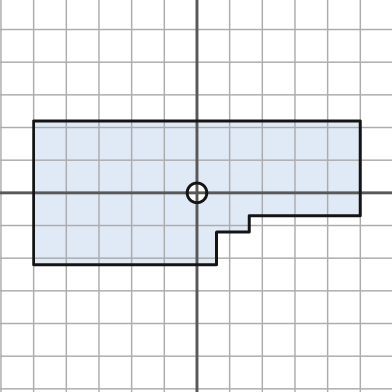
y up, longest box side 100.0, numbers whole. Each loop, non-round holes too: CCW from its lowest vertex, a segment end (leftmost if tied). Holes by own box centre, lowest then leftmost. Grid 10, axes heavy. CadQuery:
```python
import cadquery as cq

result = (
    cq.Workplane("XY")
    .moveTo(-50.0, -22.0)
    .lineTo(6.0, -22.0)
    .lineTo(6.0, -12.0)
    .lineTo(16.0, -12.0)
    .lineTo(16.0, -7.0)
    .lineTo(50.0, -7.0)
    .lineTo(50.0, 22.0)
    .lineTo(-50.0, 22.0)
    .close()
    .moveTo(0.0, 0.0)
    .circle(3.0)
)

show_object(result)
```